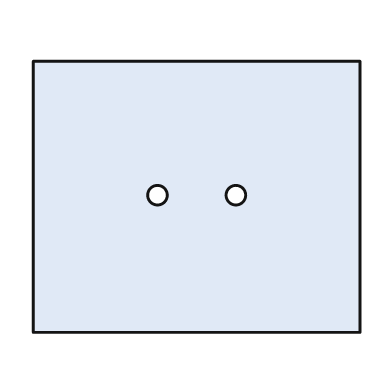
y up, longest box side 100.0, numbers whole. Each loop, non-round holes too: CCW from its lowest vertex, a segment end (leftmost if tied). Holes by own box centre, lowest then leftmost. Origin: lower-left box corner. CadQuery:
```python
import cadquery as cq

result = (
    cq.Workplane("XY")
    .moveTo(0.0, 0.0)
    .lineTo(100.0, 0.0)
    .lineTo(100.0, 83.0)
    .lineTo(0.0, 83.0)
    .close()
    .moveTo(38.0, 42.0)
    .circle(3.0)
    .moveTo(62.0, 42.0)
    .circle(3.0)
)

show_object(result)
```